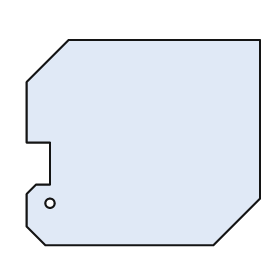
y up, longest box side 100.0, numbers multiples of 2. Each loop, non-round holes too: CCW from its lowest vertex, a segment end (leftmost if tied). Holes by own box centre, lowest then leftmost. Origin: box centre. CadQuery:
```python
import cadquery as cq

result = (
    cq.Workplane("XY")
    .moveTo(-42.0, -44.0)
    .lineTo(30.0, -44.0)
    .lineTo(50.0, -24.0)
    .lineTo(50.0, 44.0)
    .lineTo(-32.0, 44.0)
    .lineTo(-50.0, 26.0)
    .lineTo(-50.0, 0.0)
    .lineTo(-40.0, 0.0)
    .lineTo(-40.0, -18.0)
    .lineTo(-46.0, -18.0)
    .lineTo(-50.0, -22.0)
    .lineTo(-50.0, -36.0)
    .close()
    .moveTo(-40.0, -26.0)
    .circle(2.0)
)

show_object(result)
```